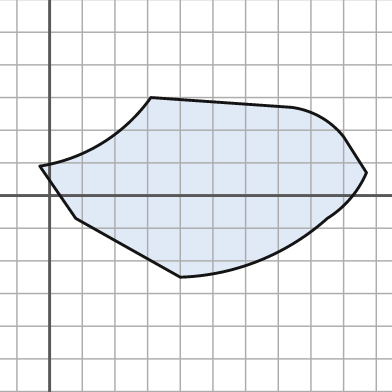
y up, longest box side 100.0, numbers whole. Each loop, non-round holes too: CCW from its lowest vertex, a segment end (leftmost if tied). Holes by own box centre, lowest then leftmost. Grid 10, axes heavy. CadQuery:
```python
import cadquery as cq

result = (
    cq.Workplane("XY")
    .moveTo(40.0, -25.0)
    .threePointArc((64.0, -20.0), (85.0, -7.0))
    .threePointArc((92.0, -1.0), (97.0, 7.0))
    .lineTo(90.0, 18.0)
    .threePointArc((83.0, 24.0), (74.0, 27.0))
    .lineTo(31.0, 30.0)
    .threePointArc((16.0, 16.0), (-3.0, 9.0))
    .lineTo(8.0, -7.0)
    .close()
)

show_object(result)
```